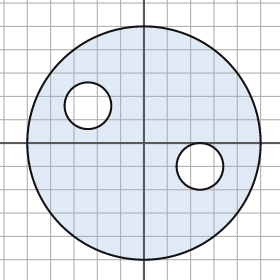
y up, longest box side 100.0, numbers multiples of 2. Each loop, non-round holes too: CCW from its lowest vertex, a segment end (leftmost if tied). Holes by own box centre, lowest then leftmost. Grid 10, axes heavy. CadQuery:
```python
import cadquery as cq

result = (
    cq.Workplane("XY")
    .moveTo(0.0, 0.0)
    .circle(50.0)
    .moveTo(24.0, -10.0)
    .circle(10.0)
    .moveTo(-24.0, 16.0)
    .circle(10.0)
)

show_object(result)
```